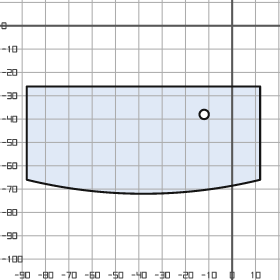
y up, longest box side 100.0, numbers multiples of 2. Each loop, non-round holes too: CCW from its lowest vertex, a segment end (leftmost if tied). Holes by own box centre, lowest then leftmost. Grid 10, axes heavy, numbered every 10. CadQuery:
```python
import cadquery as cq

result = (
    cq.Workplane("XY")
    .moveTo(-88.0, -66.0)
    .threePointArc((-38.0, -72.0), (12.0, -66.0))
    .lineTo(12.0, -26.0)
    .lineTo(-88.0, -26.0)
    .close()
    .moveTo(-12.0, -38.0)
    .circle(2.0)
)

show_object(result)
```